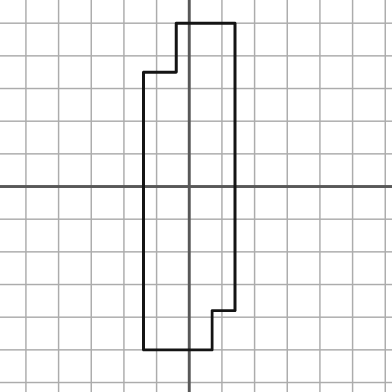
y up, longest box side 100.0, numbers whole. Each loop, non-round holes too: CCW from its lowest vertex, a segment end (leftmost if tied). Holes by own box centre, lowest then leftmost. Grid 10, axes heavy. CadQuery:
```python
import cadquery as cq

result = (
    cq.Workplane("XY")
    .moveTo(-14.0, -50.0)
    .lineTo(7.0, -50.0)
    .lineTo(7.0, -38.0)
    .lineTo(14.0, -38.0)
    .lineTo(14.0, 50.0)
    .lineTo(-4.0, 50.0)
    .lineTo(-4.0, 35.0)
    .lineTo(-14.0, 35.0)
    .close()
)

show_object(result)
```